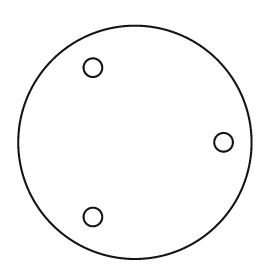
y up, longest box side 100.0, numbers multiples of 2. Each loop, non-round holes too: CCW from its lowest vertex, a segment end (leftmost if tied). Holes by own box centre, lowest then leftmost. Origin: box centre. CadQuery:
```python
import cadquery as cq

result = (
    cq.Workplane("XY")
    .moveTo(0.0, 0.0)
    .circle(50.0)
    .moveTo(-18.0, -32.0)
    .circle(4.0)
    .moveTo(38.0, 0.0)
    .circle(4.0)
    .moveTo(-18.0, 32.0)
    .circle(4.0)
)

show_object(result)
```